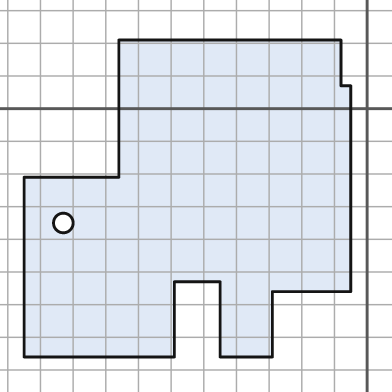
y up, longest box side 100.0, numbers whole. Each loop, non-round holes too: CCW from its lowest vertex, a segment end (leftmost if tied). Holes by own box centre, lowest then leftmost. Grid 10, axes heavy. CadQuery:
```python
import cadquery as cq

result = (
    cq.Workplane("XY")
    .moveTo(-105.0, -76.0)
    .lineTo(-59.0, -76.0)
    .lineTo(-59.0, -53.0)
    .lineTo(-45.0, -53.0)
    .lineTo(-45.0, -76.0)
    .lineTo(-29.0, -76.0)
    .lineTo(-29.0, -56.0)
    .lineTo(-5.0, -56.0)
    .lineTo(-5.0, 7.0)
    .lineTo(-8.0, 7.0)
    .lineTo(-8.0, 21.0)
    .lineTo(-76.0, 21.0)
    .lineTo(-76.0, -21.0)
    .lineTo(-105.0, -21.0)
    .close()
    .moveTo(-93.0, -35.0)
    .circle(3.0)
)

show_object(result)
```